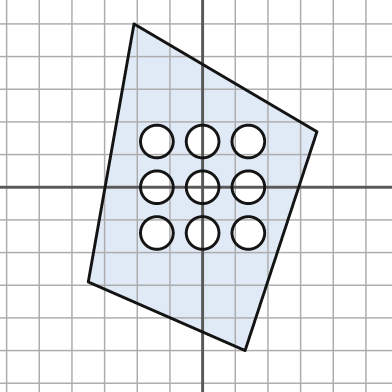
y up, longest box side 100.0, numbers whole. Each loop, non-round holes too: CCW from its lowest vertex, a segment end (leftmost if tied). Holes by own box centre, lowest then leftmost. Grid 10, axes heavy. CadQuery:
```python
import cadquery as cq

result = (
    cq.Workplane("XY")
    .moveTo(13.0, -50.0)
    .lineTo(35.0, 17.0)
    .lineTo(-21.0, 50.0)
    .lineTo(-35.0, -29.0)
    .close()
    .moveTo(-14.0, -14.0)
    .circle(5.0)
    .moveTo(0.0, -14.0)
    .circle(5.0)
    .moveTo(14.0, -14.0)
    .circle(5.0)
    .moveTo(-14.0, 0.0)
    .circle(5.0)
    .moveTo(0.0, 0.0)
    .circle(5.0)
    .moveTo(14.0, 0.0)
    .circle(5.0)
    .moveTo(-14.0, 14.0)
    .circle(5.0)
    .moveTo(0.0, 14.0)
    .circle(5.0)
    .moveTo(14.0, 14.0)
    .circle(5.0)
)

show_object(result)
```